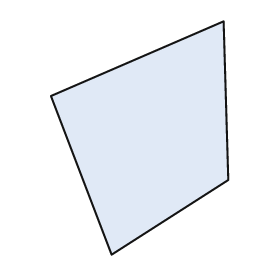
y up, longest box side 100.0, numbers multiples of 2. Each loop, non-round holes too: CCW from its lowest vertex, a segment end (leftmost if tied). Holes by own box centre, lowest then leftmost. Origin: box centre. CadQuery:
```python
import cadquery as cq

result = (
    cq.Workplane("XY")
    .moveTo(-12.0, -50.0)
    .lineTo(38.0, -18.0)
    .lineTo(36.0, 50.0)
    .lineTo(-38.0, 18.0)
    .close()
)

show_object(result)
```